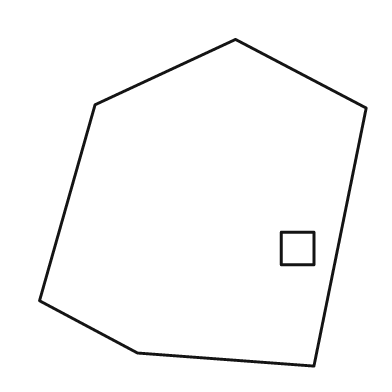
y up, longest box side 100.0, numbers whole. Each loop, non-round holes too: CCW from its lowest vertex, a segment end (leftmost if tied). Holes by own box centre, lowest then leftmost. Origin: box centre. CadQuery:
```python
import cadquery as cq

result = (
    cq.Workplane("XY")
    .moveTo(34.0, -50.0)
    .lineTo(50.0, 29.0)
    .lineTo(10.0, 50.0)
    .lineTo(-33.0, 30.0)
    .lineTo(-50.0, -30.0)
    .lineTo(-20.0, -46.0)
    .close()
    .moveTo(24.0, -19.0)
    .lineTo(34.0, -19.0)
    .lineTo(34.0, -9.0)
    .lineTo(24.0, -9.0)
    .close()
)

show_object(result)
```